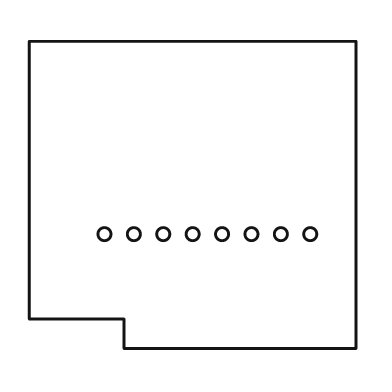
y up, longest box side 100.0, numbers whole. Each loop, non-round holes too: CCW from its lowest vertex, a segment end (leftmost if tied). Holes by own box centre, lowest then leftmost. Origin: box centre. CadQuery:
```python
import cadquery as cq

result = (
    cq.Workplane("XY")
    .moveTo(-21.0, -47.0)
    .lineTo(50.0, -47.0)
    .lineTo(50.0, 47.0)
    .lineTo(-50.0, 47.0)
    .lineTo(-50.0, -38.0)
    .lineTo(-21.0, -38.0)
    .close()
    .moveTo(-27.0, -12.0)
    .circle(2.0)
    .moveTo(-18.0, -12.0)
    .circle(2.0)
    .moveTo(-9.0, -12.0)
    .circle(2.0)
    .moveTo(0.0, -12.0)
    .circle(2.0)
    .moveTo(9.0, -12.0)
    .circle(2.0)
    .moveTo(18.0, -12.0)
    .circle(2.0)
    .moveTo(27.0, -12.0)
    .circle(2.0)
    .moveTo(36.0, -12.0)
    .circle(2.0)
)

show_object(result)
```